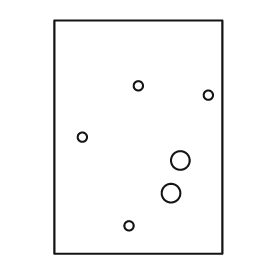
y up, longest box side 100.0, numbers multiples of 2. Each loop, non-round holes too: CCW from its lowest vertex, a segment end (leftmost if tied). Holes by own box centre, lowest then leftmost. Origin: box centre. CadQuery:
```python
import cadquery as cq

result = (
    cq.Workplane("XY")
    .moveTo(-36.0, -50.0)
    .lineTo(36.0, -50.0)
    .lineTo(36.0, 50.0)
    .lineTo(-36.0, 50.0)
    .close()
    .moveTo(-4.0, -38.0)
    .circle(2.0)
    .moveTo(14.0, -24.0)
    .circle(4.0)
    .moveTo(18.0, -10.0)
    .circle(4.0)
    .moveTo(-24.0, 0.0)
    .circle(2.0)
    .moveTo(30.0, 18.0)
    .circle(2.0)
    .moveTo(0.0, 22.0)
    .circle(2.0)
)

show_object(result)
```